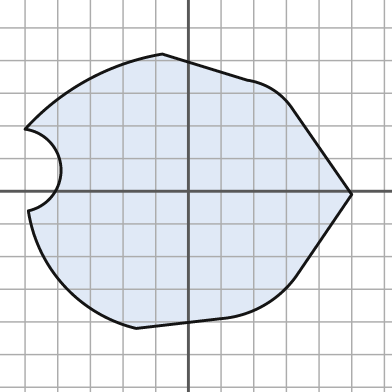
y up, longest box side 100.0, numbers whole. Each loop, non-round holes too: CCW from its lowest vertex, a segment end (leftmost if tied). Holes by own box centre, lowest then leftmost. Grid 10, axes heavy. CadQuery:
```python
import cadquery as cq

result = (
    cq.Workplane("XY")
    .moveTo(-16.0, -42.0)
    .lineTo(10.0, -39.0)
    .threePointArc((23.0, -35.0), (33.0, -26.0))
    .lineTo(50.0, -1.0)
    .lineTo(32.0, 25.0)
    .threePointArc((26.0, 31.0), (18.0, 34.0))
    .lineTo(-8.0, 42.0)
    .threePointArc((-31.0, 34.0), (-50.0, 19.0))
    .threePointArc((-39.0, 7.0), (-49.0, -6.0))
    .threePointArc((-38.0, -29.0), (-16.0, -42.0))
    .close()
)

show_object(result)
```